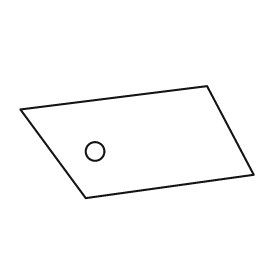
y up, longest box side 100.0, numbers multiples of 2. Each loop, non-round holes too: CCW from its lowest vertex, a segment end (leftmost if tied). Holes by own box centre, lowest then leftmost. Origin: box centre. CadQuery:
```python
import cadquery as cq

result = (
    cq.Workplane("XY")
    .moveTo(-22.0, -24.0)
    .lineTo(50.0, -14.0)
    .lineTo(30.0, 24.0)
    .lineTo(-50.0, 14.0)
    .close()
    .moveTo(-18.0, -4.0)
    .circle(4.0)
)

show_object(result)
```